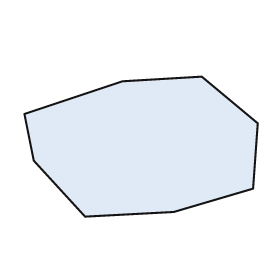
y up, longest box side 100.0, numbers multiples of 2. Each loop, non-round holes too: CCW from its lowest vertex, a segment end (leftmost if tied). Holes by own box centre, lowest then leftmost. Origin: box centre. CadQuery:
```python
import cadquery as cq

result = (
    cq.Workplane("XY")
    .moveTo(-24.0, -30.0)
    .lineTo(14.0, -28.0)
    .lineTo(48.0, -18.0)
    .lineTo(50.0, 10.0)
    .lineTo(26.0, 30.0)
    .lineTo(-8.0, 28.0)
    .lineTo(-50.0, 14.0)
    .lineTo(-46.0, -6.0)
    .close()
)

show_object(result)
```